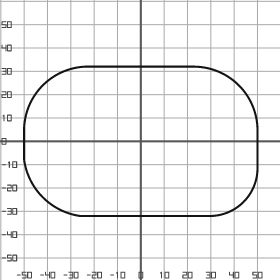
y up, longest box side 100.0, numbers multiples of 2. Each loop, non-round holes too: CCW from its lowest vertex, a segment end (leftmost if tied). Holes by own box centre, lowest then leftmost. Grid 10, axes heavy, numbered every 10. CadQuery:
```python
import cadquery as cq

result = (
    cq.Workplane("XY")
    .moveTo(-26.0, -32.0)
    .lineTo(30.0, -32.0)
    .threePointArc((44.0, -26.0), (50.0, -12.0))
    .lineTo(50.0, 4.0)
    .threePointArc((42.0, 24.0), (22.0, 32.0))
    .lineTo(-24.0, 32.0)
    .threePointArc((-42.0, 24.0), (-50.0, 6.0))
    .lineTo(-50.0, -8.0)
    .threePointArc((-42.0, -24.0), (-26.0, -32.0))
    .close()
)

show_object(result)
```